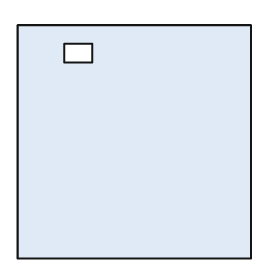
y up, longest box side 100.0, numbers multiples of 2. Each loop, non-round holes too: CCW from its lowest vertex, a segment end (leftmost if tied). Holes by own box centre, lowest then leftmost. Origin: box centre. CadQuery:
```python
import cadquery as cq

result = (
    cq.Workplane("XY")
    .moveTo(-50.0, -50.0)
    .lineTo(50.0, -50.0)
    .lineTo(50.0, 50.0)
    .lineTo(-50.0, 50.0)
    .close()
    .moveTo(-30.0, 34.0)
    .lineTo(-18.0, 34.0)
    .lineTo(-18.0, 42.0)
    .lineTo(-30.0, 42.0)
    .close()
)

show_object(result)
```